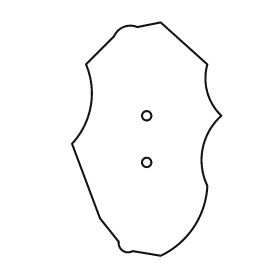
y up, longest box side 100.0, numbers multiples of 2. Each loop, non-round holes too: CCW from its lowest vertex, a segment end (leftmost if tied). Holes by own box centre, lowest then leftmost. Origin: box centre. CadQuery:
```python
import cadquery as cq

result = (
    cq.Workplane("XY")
    .moveTo(6.0, -50.0)
    .threePointArc((20.0, -38.0), (26.0, -20.0))
    .threePointArc((24.0, -4.0), (32.0, 10.0))
    .threePointArc((26.0, 20.0), (26.0, 32.0))
    .lineTo(6.0, 50.0)
    .lineTo(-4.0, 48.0)
    .threePointArc((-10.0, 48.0), (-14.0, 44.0))
    .lineTo(-26.0, 32.0)
    .threePointArc((-24.0, 14.0), (-32.0, -2.0))
    .lineTo(-20.0, -34.0)
    .lineTo(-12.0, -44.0)
    .threePointArc((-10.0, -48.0), (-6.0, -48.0))
    .close()
    .moveTo(0.0, -10.0)
    .circle(2.0)
    .moveTo(0.0, 10.0)
    .circle(2.0)
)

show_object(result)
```